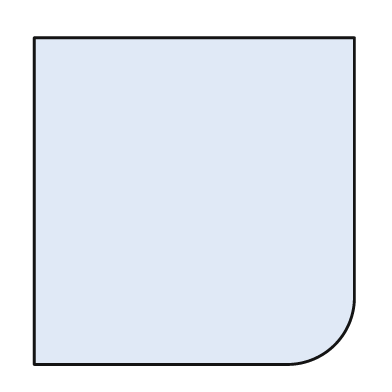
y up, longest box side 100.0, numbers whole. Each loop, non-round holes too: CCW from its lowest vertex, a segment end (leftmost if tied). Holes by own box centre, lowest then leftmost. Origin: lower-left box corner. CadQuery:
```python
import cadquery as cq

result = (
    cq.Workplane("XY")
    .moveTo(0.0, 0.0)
    .lineTo(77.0, 0.0)
    .threePointArc((92.0, 6.0), (98.0, 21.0))
    .lineTo(98.0, 100.0)
    .lineTo(0.0, 100.0)
    .close()
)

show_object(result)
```